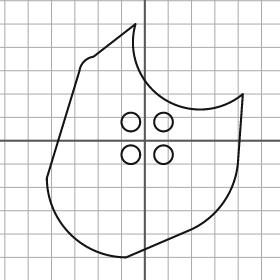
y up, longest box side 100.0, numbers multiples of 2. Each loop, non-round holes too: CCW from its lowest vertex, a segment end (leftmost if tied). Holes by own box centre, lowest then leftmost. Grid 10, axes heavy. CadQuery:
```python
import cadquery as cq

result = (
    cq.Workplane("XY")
    .moveTo(-8.0, -50.0)
    .lineTo(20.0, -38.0)
    .threePointArc((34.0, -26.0), (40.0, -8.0))
    .lineTo(42.0, 20.0)
    .threePointArc((8.0, 18.0), (-4.0, 50.0))
    .lineTo(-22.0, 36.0)
    .threePointArc((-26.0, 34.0), (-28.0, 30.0))
    .lineTo(-42.0, -16.0)
    .threePointArc((-32.0, -40.0), (-8.0, -50.0))
    .close()
    .moveTo(-6.0, -6.0)
    .circle(4.0)
    .moveTo(8.0, -6.0)
    .circle(4.0)
    .moveTo(-6.0, 8.0)
    .circle(4.0)
    .moveTo(8.0, 8.0)
    .circle(4.0)
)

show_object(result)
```